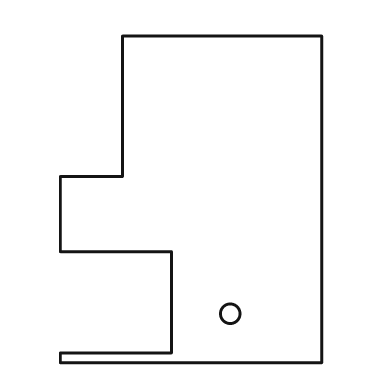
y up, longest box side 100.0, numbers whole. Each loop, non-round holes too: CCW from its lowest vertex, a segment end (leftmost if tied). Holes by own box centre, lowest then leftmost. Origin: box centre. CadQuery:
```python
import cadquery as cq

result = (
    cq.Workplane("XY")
    .moveTo(-40.0, -50.0)
    .lineTo(40.0, -50.0)
    .lineTo(40.0, 50.0)
    .lineTo(-21.0, 50.0)
    .lineTo(-21.0, 7.0)
    .lineTo(-40.0, 7.0)
    .lineTo(-40.0, -16.0)
    .lineTo(-6.0, -16.0)
    .lineTo(-6.0, -47.0)
    .lineTo(-40.0, -47.0)
    .close()
    .moveTo(12.0, -35.0)
    .circle(3.0)
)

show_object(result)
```